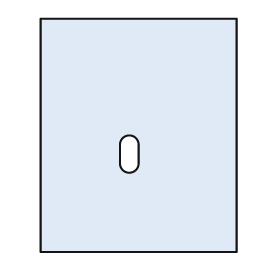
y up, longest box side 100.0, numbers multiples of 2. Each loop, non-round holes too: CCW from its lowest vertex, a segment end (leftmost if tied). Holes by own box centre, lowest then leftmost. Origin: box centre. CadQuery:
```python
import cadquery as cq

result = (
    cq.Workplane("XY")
    .moveTo(-42.0, -50.0)
    .lineTo(42.0, -50.0)
    .lineTo(42.0, 50.0)
    .lineTo(-42.0, 50.0)
    .close()
    .moveTo(-8.0, -12.0)
    .threePointArc((-4.0, -16.0), (0.0, -12.0))
    .lineTo(0.0, -4.0)
    .threePointArc((-4.0, 0.0), (-8.0, -4.0))
    .close()
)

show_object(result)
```